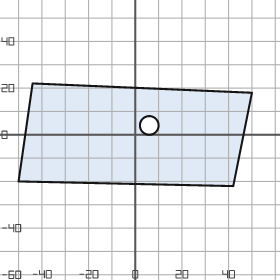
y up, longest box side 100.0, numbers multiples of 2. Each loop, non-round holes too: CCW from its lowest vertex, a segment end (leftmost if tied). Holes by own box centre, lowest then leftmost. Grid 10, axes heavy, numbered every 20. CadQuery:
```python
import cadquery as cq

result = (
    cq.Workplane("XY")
    .moveTo(42.0, -22.0)
    .lineTo(50.0, 18.0)
    .lineTo(-44.0, 22.0)
    .lineTo(-50.0, -20.0)
    .close()
    .moveTo(6.0, 4.0)
    .circle(4.0)
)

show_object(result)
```